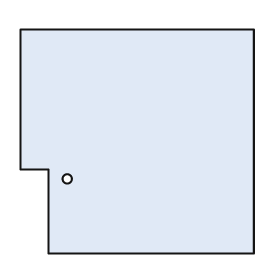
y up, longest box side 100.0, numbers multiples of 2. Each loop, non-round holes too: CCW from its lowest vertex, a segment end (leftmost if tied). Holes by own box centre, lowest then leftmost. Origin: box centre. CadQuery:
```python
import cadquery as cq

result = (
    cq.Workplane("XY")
    .moveTo(-38.0, -48.0)
    .lineTo(50.0, -48.0)
    .lineTo(50.0, 48.0)
    .lineTo(-50.0, 48.0)
    .lineTo(-50.0, -12.0)
    .lineTo(-38.0, -12.0)
    .close()
    .moveTo(-30.0, -16.0)
    .circle(2.0)
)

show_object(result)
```